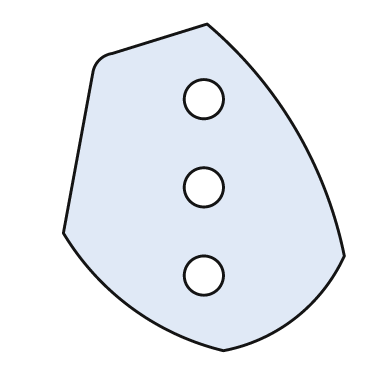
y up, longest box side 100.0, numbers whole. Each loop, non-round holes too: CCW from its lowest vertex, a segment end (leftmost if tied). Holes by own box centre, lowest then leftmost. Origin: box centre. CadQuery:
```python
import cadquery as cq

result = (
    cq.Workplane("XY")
    .moveTo(6.0, -50.0)
    .threePointArc((28.0, -40.0), (43.0, -21.0))
    .threePointArc((28.0, 18.0), (1.0, 50.0))
    .lineTo(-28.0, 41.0)
    .threePointArc((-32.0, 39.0), (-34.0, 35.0))
    .lineTo(-43.0, -14.0)
    .threePointArc((-22.0, -37.0), (6.0, -50.0))
    .close()
    .moveTo(0.0, -27.0)
    .circle(6.0)
    .moveTo(0.0, 0.0)
    .circle(6.0)
    .moveTo(0.0, 27.0)
    .circle(6.0)
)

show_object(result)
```